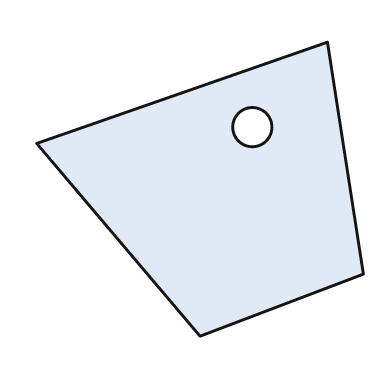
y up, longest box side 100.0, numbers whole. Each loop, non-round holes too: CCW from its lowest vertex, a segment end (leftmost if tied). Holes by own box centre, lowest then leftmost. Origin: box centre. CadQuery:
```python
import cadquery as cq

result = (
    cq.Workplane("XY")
    .moveTo(0.0, -45.0)
    .lineTo(50.0, -26.0)
    .lineTo(39.0, 45.0)
    .lineTo(-50.0, 14.0)
    .close()
    .moveTo(16.0, 19.0)
    .circle(6.0)
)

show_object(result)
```